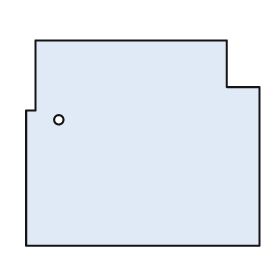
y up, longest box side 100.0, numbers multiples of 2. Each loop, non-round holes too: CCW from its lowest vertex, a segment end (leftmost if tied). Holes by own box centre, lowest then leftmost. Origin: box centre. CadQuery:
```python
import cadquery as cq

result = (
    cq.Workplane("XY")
    .moveTo(-50.0, -44.0)
    .lineTo(50.0, -44.0)
    .lineTo(50.0, 24.0)
    .lineTo(36.0, 24.0)
    .lineTo(36.0, 44.0)
    .lineTo(-46.0, 44.0)
    .lineTo(-46.0, 14.0)
    .lineTo(-50.0, 14.0)
    .close()
    .moveTo(-36.0, 10.0)
    .circle(2.0)
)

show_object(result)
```